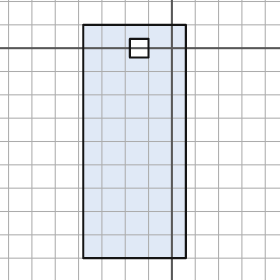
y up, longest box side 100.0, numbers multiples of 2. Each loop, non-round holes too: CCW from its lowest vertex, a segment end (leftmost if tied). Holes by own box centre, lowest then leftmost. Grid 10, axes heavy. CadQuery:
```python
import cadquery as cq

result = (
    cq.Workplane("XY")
    .moveTo(-38.0, -90.0)
    .lineTo(6.0, -90.0)
    .lineTo(6.0, 10.0)
    .lineTo(-38.0, 10.0)
    .close()
    .moveTo(-18.0, -4.0)
    .lineTo(-10.0, -4.0)
    .lineTo(-10.0, 4.0)
    .lineTo(-18.0, 4.0)
    .close()
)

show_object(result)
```